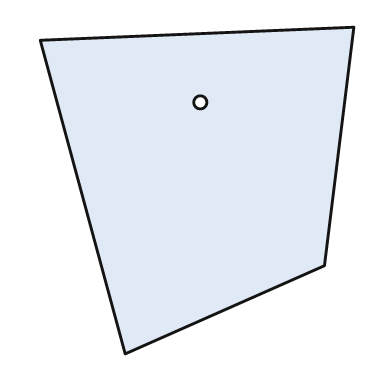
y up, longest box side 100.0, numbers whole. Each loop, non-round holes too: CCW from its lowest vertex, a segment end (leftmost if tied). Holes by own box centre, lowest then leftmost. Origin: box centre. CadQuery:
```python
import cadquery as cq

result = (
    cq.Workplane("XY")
    .moveTo(-22.0, -50.0)
    .lineTo(39.0, -23.0)
    .lineTo(48.0, 50.0)
    .lineTo(-48.0, 46.0)
    .close()
    .moveTo(1.0, 27.0)
    .circle(2.0)
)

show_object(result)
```